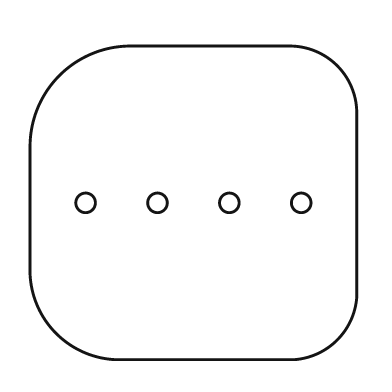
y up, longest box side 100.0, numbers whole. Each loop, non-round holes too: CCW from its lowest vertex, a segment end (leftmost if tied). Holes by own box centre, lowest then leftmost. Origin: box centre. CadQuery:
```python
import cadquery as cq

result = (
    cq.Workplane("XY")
    .moveTo(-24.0, -48.0)
    .lineTo(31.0, -48.0)
    .threePointArc((44.0, -42.0), (50.0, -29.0))
    .lineTo(50.0, 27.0)
    .threePointArc((44.0, 42.0), (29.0, 48.0))
    .lineTo(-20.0, 48.0)
    .threePointArc((-41.0, 39.0), (-50.0, 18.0))
    .lineTo(-50.0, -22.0)
    .threePointArc((-42.0, -40.0), (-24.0, -48.0))
    .close()
    .moveTo(-33.0, 0.0)
    .circle(3.0)
    .moveTo(-11.0, 0.0)
    .circle(3.0)
    .moveTo(11.0, 0.0)
    .circle(3.0)
    .moveTo(33.0, 0.0)
    .circle(3.0)
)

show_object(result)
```